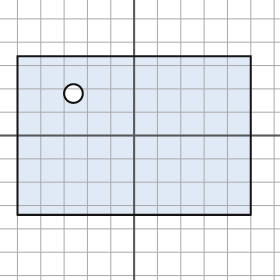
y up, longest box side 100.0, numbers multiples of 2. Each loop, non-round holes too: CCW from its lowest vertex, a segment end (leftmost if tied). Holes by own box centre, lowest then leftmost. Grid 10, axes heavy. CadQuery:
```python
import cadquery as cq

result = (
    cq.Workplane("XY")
    .moveTo(-50.0, -34.0)
    .lineTo(50.0, -34.0)
    .lineTo(50.0, 34.0)
    .lineTo(-50.0, 34.0)
    .close()
    .moveTo(-26.0, 18.0)
    .circle(4.0)
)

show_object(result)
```